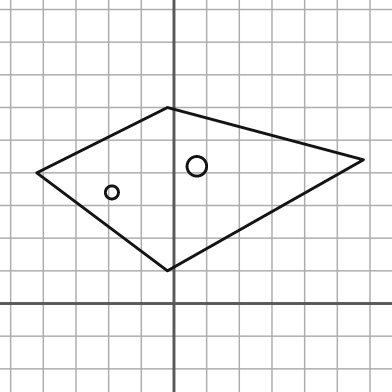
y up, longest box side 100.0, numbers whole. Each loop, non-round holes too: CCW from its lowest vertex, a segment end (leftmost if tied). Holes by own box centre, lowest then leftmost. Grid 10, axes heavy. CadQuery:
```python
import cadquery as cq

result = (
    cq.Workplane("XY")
    .moveTo(-2.0, 10.0)
    .lineTo(58.0, 44.0)
    .lineTo(-2.0, 60.0)
    .lineTo(-42.0, 40.0)
    .close()
    .moveTo(-19.0, 34.0)
    .circle(2.0)
    .moveTo(7.0, 42.0)
    .circle(3.0)
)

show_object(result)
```